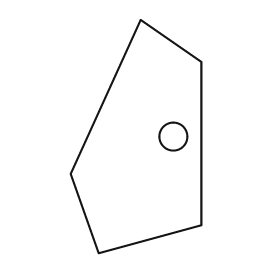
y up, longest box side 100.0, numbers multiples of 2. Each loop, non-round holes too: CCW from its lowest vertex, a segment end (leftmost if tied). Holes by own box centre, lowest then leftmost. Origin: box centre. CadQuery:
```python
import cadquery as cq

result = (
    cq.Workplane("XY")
    .moveTo(-16.0, -50.0)
    .lineTo(28.0, -38.0)
    .lineTo(28.0, 32.0)
    .lineTo(2.0, 50.0)
    .lineTo(-28.0, -16.0)
    .close()
    .moveTo(16.0, 0.0)
    .circle(6.0)
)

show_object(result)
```